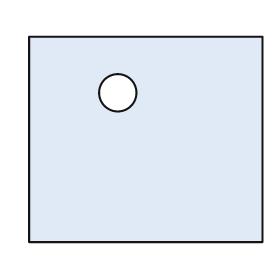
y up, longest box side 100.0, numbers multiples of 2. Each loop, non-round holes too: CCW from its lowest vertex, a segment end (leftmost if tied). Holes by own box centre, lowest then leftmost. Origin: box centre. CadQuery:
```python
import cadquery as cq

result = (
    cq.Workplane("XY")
    .moveTo(-50.0, -44.0)
    .lineTo(50.0, -44.0)
    .lineTo(50.0, 44.0)
    .lineTo(-50.0, 44.0)
    .close()
    .moveTo(-12.0, 20.0)
    .circle(8.0)
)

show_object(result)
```